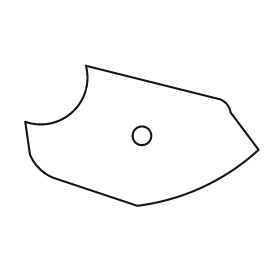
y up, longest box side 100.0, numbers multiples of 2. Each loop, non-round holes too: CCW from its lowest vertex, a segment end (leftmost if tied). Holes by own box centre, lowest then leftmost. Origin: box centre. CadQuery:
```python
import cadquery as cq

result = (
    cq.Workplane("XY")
    .moveTo(-2.0, -30.0)
    .threePointArc((26.0, -22.0), (50.0, -6.0))
    .lineTo(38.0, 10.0)
    .threePointArc((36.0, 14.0), (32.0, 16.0))
    .lineTo(-24.0, 30.0)
    .threePointArc((-30.0, 10.0), (-50.0, 6.0))
    .lineTo(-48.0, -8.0)
    .threePointArc((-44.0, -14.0), (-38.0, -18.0))
    .close()
    .moveTo(0.0, 0.0)
    .circle(4.0)
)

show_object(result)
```